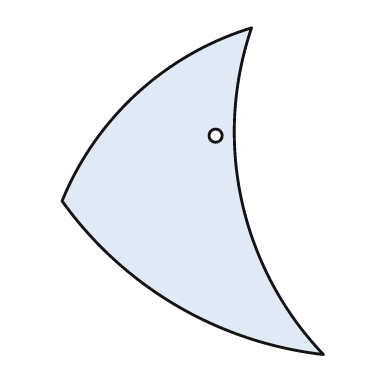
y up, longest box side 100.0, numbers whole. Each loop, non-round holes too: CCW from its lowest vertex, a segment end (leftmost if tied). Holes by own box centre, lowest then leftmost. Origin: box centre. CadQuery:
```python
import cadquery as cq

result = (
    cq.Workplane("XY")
    .moveTo(40.0, -50.0)
    .threePointArc((15.0, -3.0), (18.0, 50.0))
    .threePointArc((-17.0, 30.0), (-40.0, -3.0))
    .threePointArc((-5.0, -35.0), (40.0, -50.0))
    .close()
    .moveTo(7.0, 17.0)
    .circle(2.0)
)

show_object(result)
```